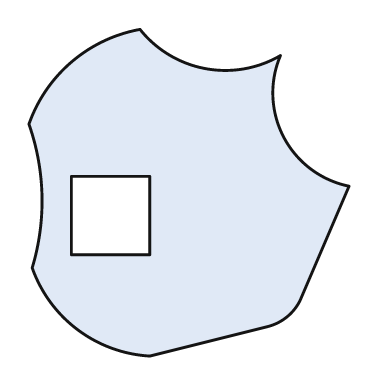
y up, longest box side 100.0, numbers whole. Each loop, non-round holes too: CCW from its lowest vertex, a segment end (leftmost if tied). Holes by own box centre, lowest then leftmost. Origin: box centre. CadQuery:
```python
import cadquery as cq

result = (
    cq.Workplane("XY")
    .moveTo(-12.0, -50.0)
    .lineTo(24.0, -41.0)
    .threePointArc((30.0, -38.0), (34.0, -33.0))
    .lineTo(49.0, 2.0)
    .threePointArc((29.0, 17.0), (28.0, 42.0))
    .threePointArc((5.0, 38.0), (-15.0, 50.0))
    .threePointArc((-36.0, 40.0), (-49.0, 21.0))
    .threePointArc((-45.0, -1.0), (-48.0, -23.0))
    .threePointArc((-34.0, -42.0), (-12.0, -50.0))
    .close()
    .moveTo(-36.0, -19.0)
    .lineTo(-12.0, -19.0)
    .lineTo(-12.0, 5.0)
    .lineTo(-36.0, 5.0)
    .close()
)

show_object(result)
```